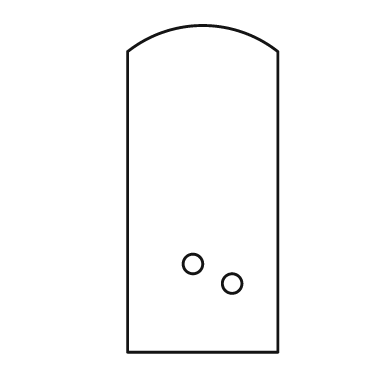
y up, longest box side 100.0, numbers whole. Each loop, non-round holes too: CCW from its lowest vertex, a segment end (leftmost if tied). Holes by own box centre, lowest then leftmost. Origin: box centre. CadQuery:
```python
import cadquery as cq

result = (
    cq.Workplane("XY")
    .moveTo(-23.0, -50.0)
    .lineTo(23.0, -50.0)
    .lineTo(23.0, 42.0)
    .threePointArc((0.0, 50.0), (-23.0, 42.0))
    .close()
    .moveTo(9.0, -29.0)
    .circle(3.0)
    .moveTo(-3.0, -23.0)
    .circle(3.0)
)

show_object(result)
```